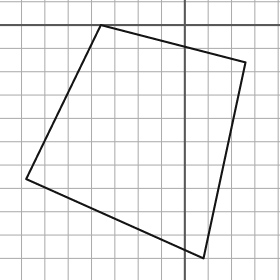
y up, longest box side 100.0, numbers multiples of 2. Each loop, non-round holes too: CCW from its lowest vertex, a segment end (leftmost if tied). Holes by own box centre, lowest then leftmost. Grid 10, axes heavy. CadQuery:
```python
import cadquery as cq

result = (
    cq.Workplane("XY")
    .moveTo(8.0, -100.0)
    .lineTo(26.0, -16.0)
    .lineTo(-36.0, 0.0)
    .lineTo(-68.0, -66.0)
    .close()
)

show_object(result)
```